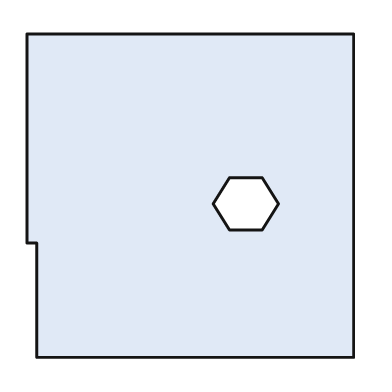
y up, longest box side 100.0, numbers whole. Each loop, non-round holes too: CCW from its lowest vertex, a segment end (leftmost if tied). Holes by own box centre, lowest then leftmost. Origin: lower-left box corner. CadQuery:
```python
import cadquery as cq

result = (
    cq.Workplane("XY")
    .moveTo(3.0, 0.0)
    .lineTo(100.0, 0.0)
    .lineTo(100.0, 99.0)
    .lineTo(0.0, 99.0)
    .lineTo(0.0, 35.0)
    .lineTo(3.0, 35.0)
    .close()
    .moveTo(62.0, 39.0)
    .lineTo(72.0, 39.0)
    .lineTo(77.0, 47.0)
    .lineTo(72.0, 55.0)
    .lineTo(62.0, 55.0)
    .lineTo(57.0, 47.0)
    .close()
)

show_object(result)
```